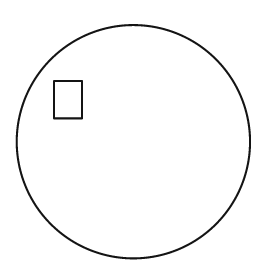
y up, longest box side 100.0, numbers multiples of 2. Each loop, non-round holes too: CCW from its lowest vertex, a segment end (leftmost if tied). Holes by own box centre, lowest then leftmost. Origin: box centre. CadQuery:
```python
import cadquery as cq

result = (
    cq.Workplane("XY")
    .moveTo(0.0, 0.0)
    .circle(50.0)
    .moveTo(-34.0, 10.0)
    .lineTo(-22.0, 10.0)
    .lineTo(-22.0, 26.0)
    .lineTo(-34.0, 26.0)
    .close()
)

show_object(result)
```